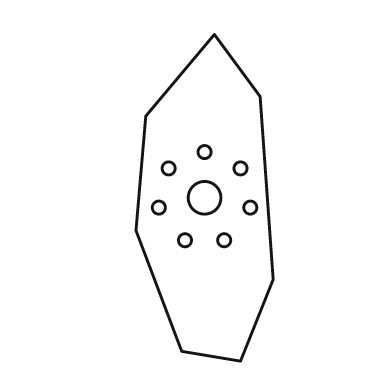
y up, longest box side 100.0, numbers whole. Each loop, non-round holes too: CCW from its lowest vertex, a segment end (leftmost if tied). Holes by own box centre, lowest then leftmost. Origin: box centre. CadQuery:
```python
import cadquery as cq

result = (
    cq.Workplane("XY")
    .moveTo(11.0, -50.0)
    .lineTo(21.0, -25.0)
    .lineTo(17.0, 31.0)
    .lineTo(3.0, 50.0)
    .lineTo(-18.0, 25.0)
    .lineTo(-21.0, -10.0)
    .lineTo(-7.0, -47.0)
    .close()
    .moveTo(-6.0, -13.0)
    .circle(2.0)
    .moveTo(6.0, -13.0)
    .circle(2.0)
    .moveTo(-14.0, -3.0)
    .circle(2.0)
    .moveTo(14.0, -3.0)
    .circle(2.0)
    .moveTo(0.0, 0.0)
    .circle(5.0)
    .moveTo(-11.0, 9.0)
    .circle(2.0)
    .moveTo(11.0, 9.0)
    .circle(2.0)
    .moveTo(0.0, 14.0)
    .circle(2.0)
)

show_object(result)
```